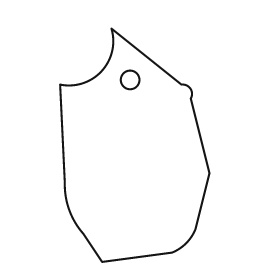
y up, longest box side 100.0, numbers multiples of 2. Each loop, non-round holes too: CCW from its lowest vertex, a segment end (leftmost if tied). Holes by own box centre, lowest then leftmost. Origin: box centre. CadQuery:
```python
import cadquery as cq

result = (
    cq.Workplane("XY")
    .moveTo(-14.0, -50.0)
    .lineTo(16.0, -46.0)
    .threePointArc((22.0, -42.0), (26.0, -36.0))
    .lineTo(32.0, -12.0)
    .lineTo(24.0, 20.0)
    .threePointArc((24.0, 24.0), (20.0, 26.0))
    .lineTo(-10.0, 50.0)
    .threePointArc((-14.0, 32.0), (-32.0, 26.0))
    .lineTo(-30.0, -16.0)
    .threePointArc((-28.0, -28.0), (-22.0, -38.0))
    .close()
    .moveTo(-2.0, 28.0)
    .circle(4.0)
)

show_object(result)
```